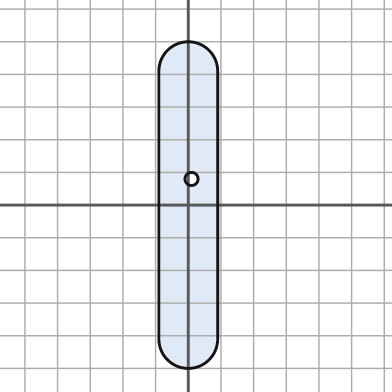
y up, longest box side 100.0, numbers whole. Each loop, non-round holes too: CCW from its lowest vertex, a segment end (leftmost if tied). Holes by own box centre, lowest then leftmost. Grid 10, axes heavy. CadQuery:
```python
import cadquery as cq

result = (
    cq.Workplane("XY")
    .moveTo(-9.0, -41.0)
    .threePointArc((0.0, -50.0), (9.0, -41.0))
    .lineTo(9.0, 41.0)
    .threePointArc((0.0, 50.0), (-9.0, 41.0))
    .close()
    .moveTo(1.0, 8.0)
    .circle(2.0)
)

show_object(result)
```